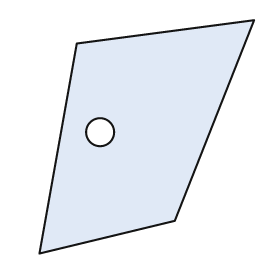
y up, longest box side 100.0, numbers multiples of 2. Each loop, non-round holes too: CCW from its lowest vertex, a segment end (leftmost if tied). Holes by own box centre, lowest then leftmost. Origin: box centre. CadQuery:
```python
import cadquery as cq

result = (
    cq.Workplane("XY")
    .moveTo(-46.0, -50.0)
    .lineTo(12.0, -36.0)
    .lineTo(46.0, 50.0)
    .lineTo(-30.0, 40.0)
    .close()
    .moveTo(-20.0, 2.0)
    .circle(6.0)
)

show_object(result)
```